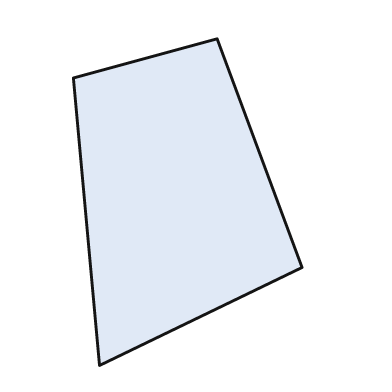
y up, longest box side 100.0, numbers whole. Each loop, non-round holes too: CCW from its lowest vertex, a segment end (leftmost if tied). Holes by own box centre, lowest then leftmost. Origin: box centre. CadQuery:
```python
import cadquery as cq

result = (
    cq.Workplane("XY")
    .moveTo(-27.0, -50.0)
    .lineTo(35.0, -20.0)
    .lineTo(9.0, 50.0)
    .lineTo(-35.0, 38.0)
    .close()
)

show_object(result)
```